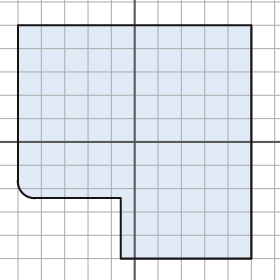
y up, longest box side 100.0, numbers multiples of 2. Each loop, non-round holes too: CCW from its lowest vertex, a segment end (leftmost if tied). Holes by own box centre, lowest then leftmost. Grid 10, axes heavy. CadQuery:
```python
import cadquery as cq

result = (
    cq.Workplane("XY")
    .moveTo(-6.0, -50.0)
    .lineTo(50.0, -50.0)
    .lineTo(50.0, 50.0)
    .lineTo(-50.0, 50.0)
    .lineTo(-50.0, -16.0)
    .threePointArc((-48.0, -22.0), (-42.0, -24.0))
    .lineTo(-6.0, -24.0)
    .close()
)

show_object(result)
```